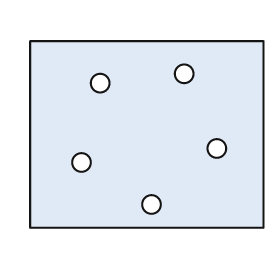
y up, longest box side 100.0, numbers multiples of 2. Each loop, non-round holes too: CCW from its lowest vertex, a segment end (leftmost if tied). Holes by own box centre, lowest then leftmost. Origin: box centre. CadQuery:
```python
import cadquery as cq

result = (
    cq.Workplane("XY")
    .moveTo(-50.0, -40.0)
    .lineTo(50.0, -40.0)
    .lineTo(50.0, 40.0)
    .lineTo(-50.0, 40.0)
    .close()
    .moveTo(2.0, -30.0)
    .circle(4.0)
    .moveTo(-28.0, -12.0)
    .circle(4.0)
    .moveTo(30.0, -6.0)
    .circle(4.0)
    .moveTo(-20.0, 22.0)
    .circle(4.0)
    .moveTo(16.0, 26.0)
    .circle(4.0)
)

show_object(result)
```